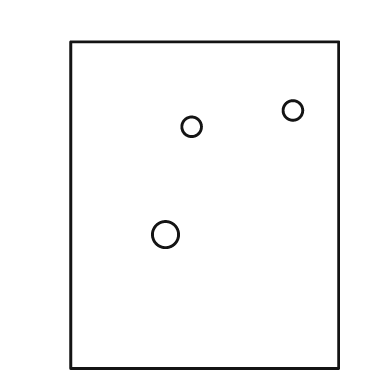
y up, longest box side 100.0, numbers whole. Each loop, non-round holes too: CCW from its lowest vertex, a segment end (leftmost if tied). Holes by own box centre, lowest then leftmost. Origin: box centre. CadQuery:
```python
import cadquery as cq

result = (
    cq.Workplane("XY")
    .moveTo(-41.0, -50.0)
    .lineTo(41.0, -50.0)
    .lineTo(41.0, 50.0)
    .lineTo(-41.0, 50.0)
    .close()
    .moveTo(-12.0, -9.0)
    .circle(4.0)
    .moveTo(-4.0, 24.0)
    .circle(3.0)
    .moveTo(27.0, 29.0)
    .circle(3.0)
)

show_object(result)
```